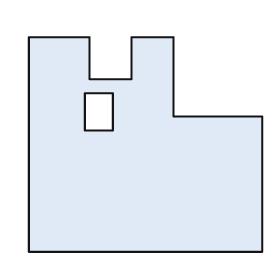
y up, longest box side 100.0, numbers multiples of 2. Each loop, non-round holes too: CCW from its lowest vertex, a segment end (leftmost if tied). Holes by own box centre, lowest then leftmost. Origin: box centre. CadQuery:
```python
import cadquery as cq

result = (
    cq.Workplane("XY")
    .moveTo(-50.0, -46.0)
    .lineTo(50.0, -46.0)
    .lineTo(50.0, 12.0)
    .lineTo(12.0, 12.0)
    .lineTo(12.0, 46.0)
    .lineTo(-6.0, 46.0)
    .lineTo(-6.0, 28.0)
    .lineTo(-24.0, 28.0)
    .lineTo(-24.0, 46.0)
    .lineTo(-50.0, 46.0)
    .close()
    .moveTo(-26.0, 6.0)
    .lineTo(-14.0, 6.0)
    .lineTo(-14.0, 22.0)
    .lineTo(-26.0, 22.0)
    .close()
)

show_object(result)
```